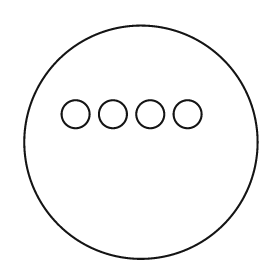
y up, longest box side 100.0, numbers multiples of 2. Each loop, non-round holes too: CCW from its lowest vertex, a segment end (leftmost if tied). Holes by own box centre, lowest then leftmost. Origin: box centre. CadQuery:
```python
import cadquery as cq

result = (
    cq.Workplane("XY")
    .moveTo(0.0, 0.0)
    .circle(50.0)
    .moveTo(-28.0, 12.0)
    .circle(6.0)
    .moveTo(-12.0, 12.0)
    .circle(6.0)
    .moveTo(4.0, 12.0)
    .circle(6.0)
    .moveTo(20.0, 12.0)
    .circle(6.0)
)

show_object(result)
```